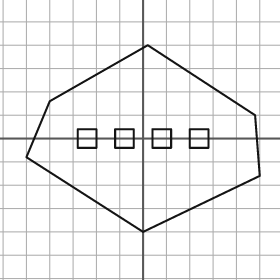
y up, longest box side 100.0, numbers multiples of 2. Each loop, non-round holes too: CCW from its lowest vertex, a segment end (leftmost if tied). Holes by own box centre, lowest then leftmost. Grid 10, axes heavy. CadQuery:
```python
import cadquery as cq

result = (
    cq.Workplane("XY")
    .moveTo(0.0, -40.0)
    .lineTo(50.0, -16.0)
    .lineTo(48.0, 10.0)
    .lineTo(2.0, 40.0)
    .lineTo(-40.0, 16.0)
    .lineTo(-50.0, -8.0)
    .close()
    .moveTo(-28.0, -4.0)
    .lineTo(-20.0, -4.0)
    .lineTo(-20.0, 4.0)
    .lineTo(-28.0, 4.0)
    .close()
    .moveTo(-12.0, -4.0)
    .lineTo(-4.0, -4.0)
    .lineTo(-4.0, 4.0)
    .lineTo(-12.0, 4.0)
    .close()
    .moveTo(4.0, -4.0)
    .lineTo(12.0, -4.0)
    .lineTo(12.0, 4.0)
    .lineTo(4.0, 4.0)
    .close()
    .moveTo(20.0, -4.0)
    .lineTo(28.0, -4.0)
    .lineTo(28.0, 4.0)
    .lineTo(20.0, 4.0)
    .close()
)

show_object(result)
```